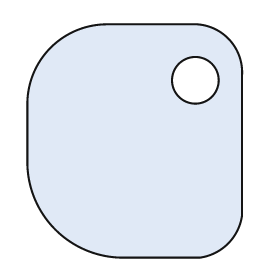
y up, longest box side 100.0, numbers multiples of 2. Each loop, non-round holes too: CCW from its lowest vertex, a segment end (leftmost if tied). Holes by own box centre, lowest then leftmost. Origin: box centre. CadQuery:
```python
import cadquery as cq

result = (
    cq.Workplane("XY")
    .moveTo(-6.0, -50.0)
    .lineTo(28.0, -50.0)
    .threePointArc((40.0, -44.0), (46.0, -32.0))
    .lineTo(46.0, 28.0)
    .threePointArc((40.0, 44.0), (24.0, 50.0))
    .lineTo(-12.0, 50.0)
    .threePointArc((-36.0, 40.0), (-46.0, 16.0))
    .lineTo(-46.0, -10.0)
    .threePointArc((-34.0, -38.0), (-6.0, -50.0))
    .close()
    .moveTo(26.0, 26.0)
    .circle(10.0)
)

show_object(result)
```